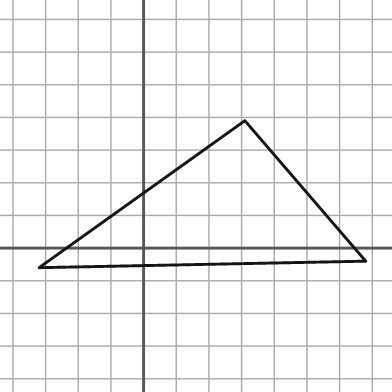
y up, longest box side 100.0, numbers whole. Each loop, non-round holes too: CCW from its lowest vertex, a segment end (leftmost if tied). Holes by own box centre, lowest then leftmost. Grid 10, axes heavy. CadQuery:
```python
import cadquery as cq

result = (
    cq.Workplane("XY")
    .moveTo(-32.0, -6.0)
    .lineTo(68.0, -4.0)
    .lineTo(31.0, 39.0)
    .close()
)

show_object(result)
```